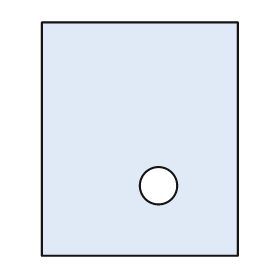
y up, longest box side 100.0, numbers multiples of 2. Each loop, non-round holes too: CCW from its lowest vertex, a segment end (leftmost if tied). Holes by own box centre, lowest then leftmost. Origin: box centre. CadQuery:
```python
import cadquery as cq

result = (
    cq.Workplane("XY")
    .moveTo(-42.0, -50.0)
    .lineTo(42.0, -50.0)
    .lineTo(42.0, 50.0)
    .lineTo(-42.0, 50.0)
    .close()
    .moveTo(8.0, -20.0)
    .circle(8.0)
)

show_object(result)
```